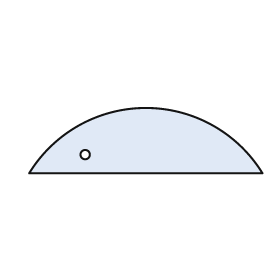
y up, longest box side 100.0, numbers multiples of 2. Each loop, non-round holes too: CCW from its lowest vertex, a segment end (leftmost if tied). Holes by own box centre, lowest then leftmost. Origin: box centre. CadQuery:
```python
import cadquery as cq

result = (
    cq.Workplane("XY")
    .moveTo(-50.0, -14.0)
    .lineTo(50.0, -14.0)
    .threePointArc((0.0, 14.0), (-50.0, -14.0))
    .close()
    .moveTo(-26.0, -6.0)
    .circle(2.0)
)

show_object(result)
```